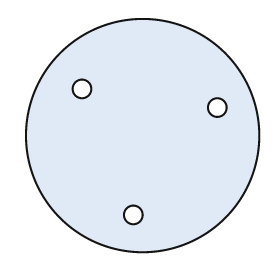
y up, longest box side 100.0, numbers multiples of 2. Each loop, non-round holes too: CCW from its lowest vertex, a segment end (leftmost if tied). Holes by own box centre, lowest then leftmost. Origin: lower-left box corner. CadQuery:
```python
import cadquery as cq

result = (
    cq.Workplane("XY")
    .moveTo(50.0, 50.0)
    .circle(50.0)
    .moveTo(46.0, 16.0)
    .circle(4.0)
    .moveTo(82.0, 62.0)
    .circle(4.0)
    .moveTo(24.0, 70.0)
    .circle(4.0)
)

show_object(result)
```